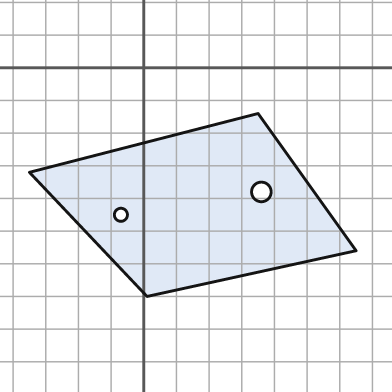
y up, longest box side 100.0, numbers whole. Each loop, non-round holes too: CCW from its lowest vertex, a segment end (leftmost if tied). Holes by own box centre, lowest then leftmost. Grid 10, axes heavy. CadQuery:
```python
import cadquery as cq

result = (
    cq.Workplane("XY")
    .moveTo(1.0, -70.0)
    .lineTo(65.0, -56.0)
    .lineTo(35.0, -14.0)
    .lineTo(-35.0, -32.0)
    .close()
    .moveTo(-7.0, -45.0)
    .circle(2.0)
    .moveTo(36.0, -38.0)
    .circle(3.0)
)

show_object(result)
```